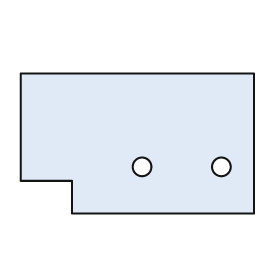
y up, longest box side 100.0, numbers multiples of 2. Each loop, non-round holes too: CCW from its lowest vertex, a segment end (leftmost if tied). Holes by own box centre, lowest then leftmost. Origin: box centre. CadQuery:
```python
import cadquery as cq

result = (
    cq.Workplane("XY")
    .moveTo(-28.0, -30.0)
    .lineTo(50.0, -30.0)
    .lineTo(50.0, 30.0)
    .lineTo(-50.0, 30.0)
    .lineTo(-50.0, -16.0)
    .lineTo(-28.0, -16.0)
    .close()
    .moveTo(2.0, -10.0)
    .circle(4.0)
    .moveTo(36.0, -10.0)
    .circle(4.0)
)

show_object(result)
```